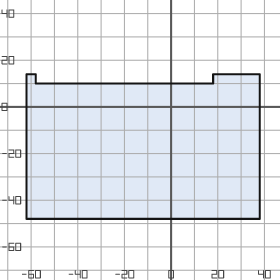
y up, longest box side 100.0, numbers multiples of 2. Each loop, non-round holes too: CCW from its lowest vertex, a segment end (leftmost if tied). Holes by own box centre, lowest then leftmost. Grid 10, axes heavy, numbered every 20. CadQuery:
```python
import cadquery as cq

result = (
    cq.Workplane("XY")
    .moveTo(-62.0, -48.0)
    .lineTo(38.0, -48.0)
    .lineTo(38.0, 14.0)
    .lineTo(18.0, 14.0)
    .lineTo(18.0, 10.0)
    .lineTo(-58.0, 10.0)
    .lineTo(-58.0, 14.0)
    .lineTo(-62.0, 14.0)
    .close()
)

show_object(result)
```